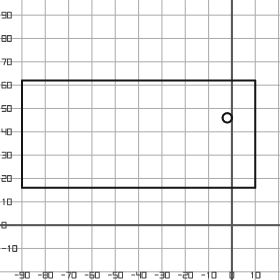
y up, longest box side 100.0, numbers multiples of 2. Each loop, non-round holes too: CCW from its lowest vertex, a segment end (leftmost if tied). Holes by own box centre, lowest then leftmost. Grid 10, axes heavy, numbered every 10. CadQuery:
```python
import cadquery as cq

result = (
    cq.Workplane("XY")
    .moveTo(-90.0, 16.0)
    .lineTo(10.0, 16.0)
    .lineTo(10.0, 62.0)
    .lineTo(-90.0, 62.0)
    .close()
    .moveTo(-2.0, 46.0)
    .circle(2.0)
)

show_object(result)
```